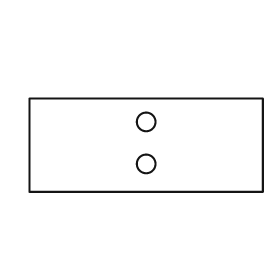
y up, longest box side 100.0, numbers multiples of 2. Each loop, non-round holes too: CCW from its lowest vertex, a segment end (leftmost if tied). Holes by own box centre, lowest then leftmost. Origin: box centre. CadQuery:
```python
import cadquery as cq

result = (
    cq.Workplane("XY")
    .moveTo(-50.0, -20.0)
    .lineTo(50.0, -20.0)
    .lineTo(50.0, 20.0)
    .lineTo(-50.0, 20.0)
    .close()
    .moveTo(0.0, -8.0)
    .circle(4.0)
    .moveTo(0.0, 10.0)
    .circle(4.0)
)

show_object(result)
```